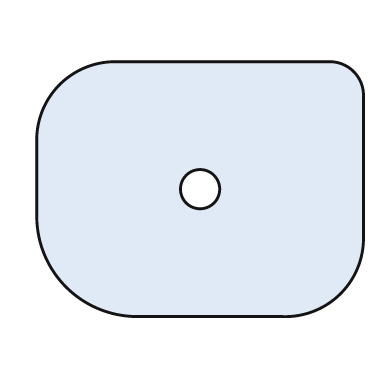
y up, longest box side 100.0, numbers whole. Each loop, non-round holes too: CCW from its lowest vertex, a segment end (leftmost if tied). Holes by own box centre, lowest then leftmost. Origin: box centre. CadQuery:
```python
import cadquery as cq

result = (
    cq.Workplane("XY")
    .moveTo(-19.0, -39.0)
    .lineTo(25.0, -39.0)
    .threePointArc((43.0, -32.0), (50.0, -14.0))
    .lineTo(50.0, 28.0)
    .threePointArc((47.0, 36.0), (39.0, 39.0))
    .lineTo(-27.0, 39.0)
    .threePointArc((-43.0, 32.0), (-50.0, 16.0))
    .lineTo(-50.0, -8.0)
    .threePointArc((-41.0, -30.0), (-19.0, -39.0))
    .close()
    .moveTo(0.0, 0.0)
    .circle(6.0)
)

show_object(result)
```